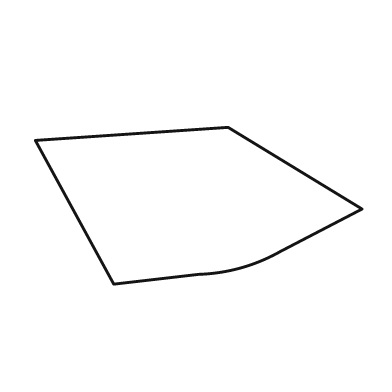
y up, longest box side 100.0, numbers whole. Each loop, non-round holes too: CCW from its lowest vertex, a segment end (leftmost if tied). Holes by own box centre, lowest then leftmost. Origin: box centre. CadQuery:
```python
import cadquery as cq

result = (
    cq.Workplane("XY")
    .moveTo(-26.0, -24.0)
    .lineTo(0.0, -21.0)
    .threePointArc((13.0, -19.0), (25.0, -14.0))
    .lineTo(50.0, -1.0)
    .lineTo(9.0, 24.0)
    .lineTo(-50.0, 20.0)
    .close()
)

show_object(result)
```